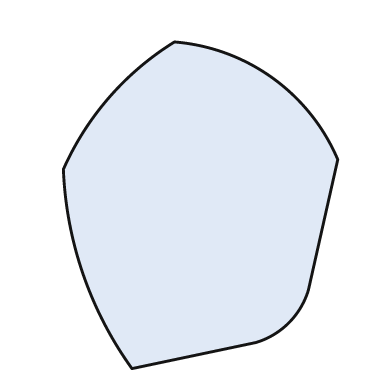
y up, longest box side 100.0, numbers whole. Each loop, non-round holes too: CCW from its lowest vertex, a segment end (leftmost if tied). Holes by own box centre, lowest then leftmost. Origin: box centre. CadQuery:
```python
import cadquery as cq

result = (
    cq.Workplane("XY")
    .moveTo(-21.0, -50.0)
    .lineTo(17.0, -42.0)
    .threePointArc((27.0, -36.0), (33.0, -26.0))
    .lineTo(42.0, 14.0)
    .threePointArc((22.0, 39.0), (-8.0, 50.0))
    .threePointArc((-28.0, 33.0), (-42.0, 11.0))
    .threePointArc((-36.0, -21.0), (-21.0, -50.0))
    .close()
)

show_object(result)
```